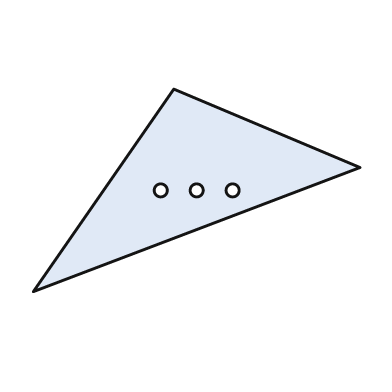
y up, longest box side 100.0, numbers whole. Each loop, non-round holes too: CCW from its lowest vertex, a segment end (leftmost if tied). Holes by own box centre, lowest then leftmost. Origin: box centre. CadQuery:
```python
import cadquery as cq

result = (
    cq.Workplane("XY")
    .moveTo(-50.0, -31.0)
    .lineTo(50.0, 7.0)
    .lineTo(-7.0, 31.0)
    .close()
    .moveTo(-11.0, 0.0)
    .circle(2.0)
    .moveTo(0.0, 0.0)
    .circle(2.0)
    .moveTo(11.0, 0.0)
    .circle(2.0)
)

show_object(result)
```